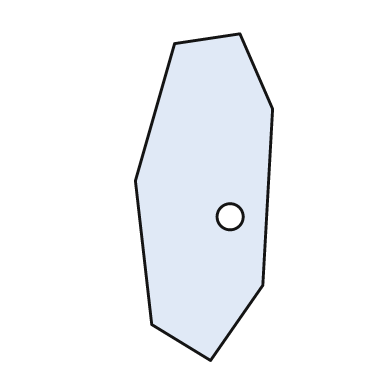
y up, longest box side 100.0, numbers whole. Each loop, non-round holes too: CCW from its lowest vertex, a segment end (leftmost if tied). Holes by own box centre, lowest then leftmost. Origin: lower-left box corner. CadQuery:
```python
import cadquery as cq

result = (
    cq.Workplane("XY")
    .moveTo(23.0, 0.0)
    .lineTo(39.0, 23.0)
    .lineTo(42.0, 77.0)
    .lineTo(32.0, 100.0)
    .lineTo(12.0, 97.0)
    .lineTo(0.0, 55.0)
    .lineTo(5.0, 11.0)
    .close()
    .moveTo(29.0, 44.0)
    .circle(4.0)
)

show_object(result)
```